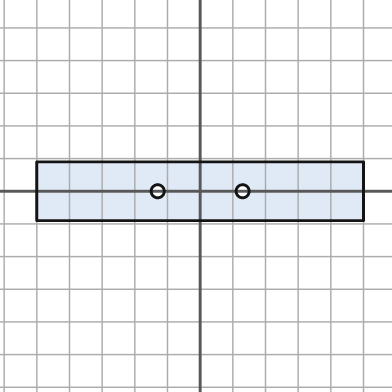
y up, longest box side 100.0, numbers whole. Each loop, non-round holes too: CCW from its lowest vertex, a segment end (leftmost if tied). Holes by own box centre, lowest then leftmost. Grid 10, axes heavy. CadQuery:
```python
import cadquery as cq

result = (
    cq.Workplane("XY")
    .moveTo(-50.0, -9.0)
    .lineTo(50.0, -9.0)
    .lineTo(50.0, 9.0)
    .lineTo(-50.0, 9.0)
    .close()
    .moveTo(-13.0, 0.0)
    .circle(2.0)
    .moveTo(13.0, 0.0)
    .circle(2.0)
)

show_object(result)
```